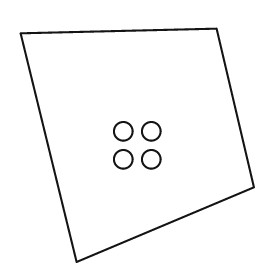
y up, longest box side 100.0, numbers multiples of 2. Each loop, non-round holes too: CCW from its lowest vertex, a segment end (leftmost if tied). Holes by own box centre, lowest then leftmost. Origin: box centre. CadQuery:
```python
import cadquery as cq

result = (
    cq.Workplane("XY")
    .moveTo(-26.0, -50.0)
    .lineTo(50.0, -18.0)
    .lineTo(34.0, 50.0)
    .lineTo(-50.0, 48.0)
    .close()
    .moveTo(-6.0, -6.0)
    .circle(4.0)
    .moveTo(6.0, -6.0)
    .circle(4.0)
    .moveTo(-6.0, 6.0)
    .circle(4.0)
    .moveTo(6.0, 6.0)
    .circle(4.0)
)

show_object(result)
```